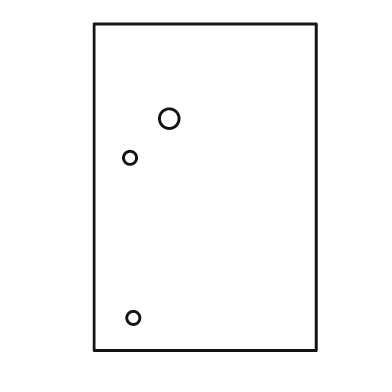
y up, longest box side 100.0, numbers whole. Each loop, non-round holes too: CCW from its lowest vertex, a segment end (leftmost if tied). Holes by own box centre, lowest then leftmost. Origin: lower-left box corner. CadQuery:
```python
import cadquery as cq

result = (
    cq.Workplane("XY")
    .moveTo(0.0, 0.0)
    .lineTo(68.0, 0.0)
    .lineTo(68.0, 100.0)
    .lineTo(0.0, 100.0)
    .close()
    .moveTo(12.0, 10.0)
    .circle(2.0)
    .moveTo(11.0, 59.0)
    .circle(2.0)
    .moveTo(23.0, 71.0)
    .circle(3.0)
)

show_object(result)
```